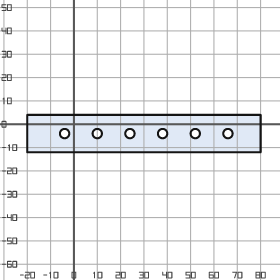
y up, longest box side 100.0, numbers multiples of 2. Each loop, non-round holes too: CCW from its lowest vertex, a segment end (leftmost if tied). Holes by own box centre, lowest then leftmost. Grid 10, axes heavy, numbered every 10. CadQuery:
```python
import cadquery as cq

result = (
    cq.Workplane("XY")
    .moveTo(-20.0, -12.0)
    .lineTo(80.0, -12.0)
    .lineTo(80.0, 4.0)
    .lineTo(-20.0, 4.0)
    .close()
    .moveTo(-4.0, -4.0)
    .circle(2.0)
    .moveTo(10.0, -4.0)
    .circle(2.0)
    .moveTo(24.0, -4.0)
    .circle(2.0)
    .moveTo(38.0, -4.0)
    .circle(2.0)
    .moveTo(52.0, -4.0)
    .circle(2.0)
    .moveTo(66.0, -4.0)
    .circle(2.0)
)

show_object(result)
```